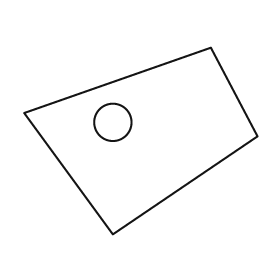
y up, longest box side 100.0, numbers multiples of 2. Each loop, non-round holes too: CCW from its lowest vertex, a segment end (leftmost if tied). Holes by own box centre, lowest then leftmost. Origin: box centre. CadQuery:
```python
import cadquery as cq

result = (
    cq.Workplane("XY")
    .moveTo(-12.0, -40.0)
    .lineTo(50.0, 2.0)
    .lineTo(30.0, 40.0)
    .lineTo(-50.0, 12.0)
    .close()
    .moveTo(-12.0, 8.0)
    .circle(8.0)
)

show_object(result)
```